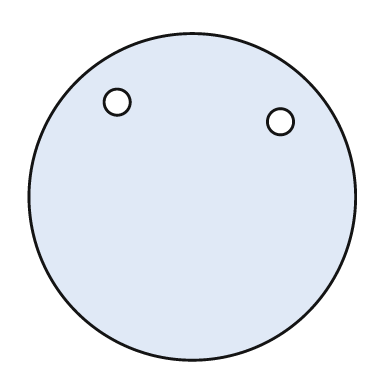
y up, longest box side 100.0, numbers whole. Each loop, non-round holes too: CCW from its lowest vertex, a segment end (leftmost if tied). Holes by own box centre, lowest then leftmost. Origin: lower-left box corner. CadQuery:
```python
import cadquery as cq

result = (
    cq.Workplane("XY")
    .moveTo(50.0, 50.0)
    .circle(50.0)
    .moveTo(77.0, 73.0)
    .circle(4.0)
    .moveTo(27.0, 79.0)
    .circle(4.0)
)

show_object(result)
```